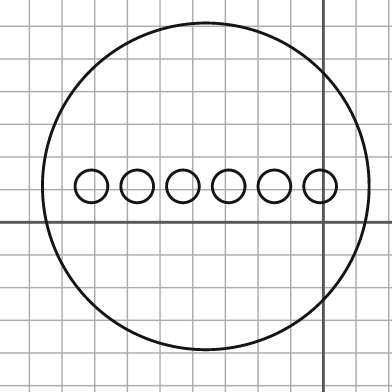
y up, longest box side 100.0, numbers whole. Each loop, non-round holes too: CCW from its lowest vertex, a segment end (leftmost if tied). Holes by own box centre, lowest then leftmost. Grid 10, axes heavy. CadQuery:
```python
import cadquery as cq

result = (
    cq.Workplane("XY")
    .moveTo(-36.0, 11.0)
    .circle(50.0)
    .moveTo(-71.0, 11.0)
    .circle(5.0)
    .moveTo(-57.0, 11.0)
    .circle(5.0)
    .moveTo(-43.0, 11.0)
    .circle(5.0)
    .moveTo(-29.0, 11.0)
    .circle(5.0)
    .moveTo(-15.0, 11.0)
    .circle(5.0)
    .moveTo(-1.0, 11.0)
    .circle(5.0)
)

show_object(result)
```